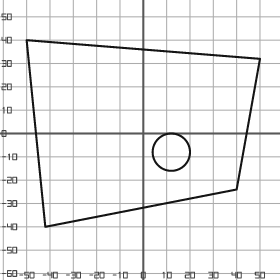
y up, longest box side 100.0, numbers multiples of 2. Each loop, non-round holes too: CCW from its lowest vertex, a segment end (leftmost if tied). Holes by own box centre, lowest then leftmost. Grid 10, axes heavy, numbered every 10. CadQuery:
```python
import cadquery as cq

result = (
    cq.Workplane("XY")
    .moveTo(-42.0, -40.0)
    .lineTo(40.0, -24.0)
    .lineTo(50.0, 32.0)
    .lineTo(-50.0, 40.0)
    .close()
    .moveTo(12.0, -8.0)
    .circle(8.0)
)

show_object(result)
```